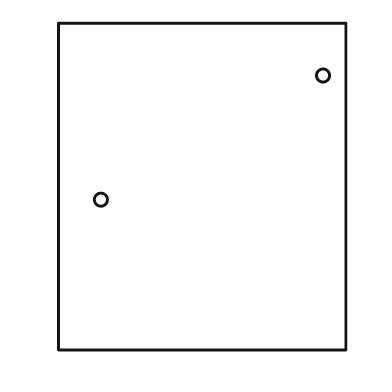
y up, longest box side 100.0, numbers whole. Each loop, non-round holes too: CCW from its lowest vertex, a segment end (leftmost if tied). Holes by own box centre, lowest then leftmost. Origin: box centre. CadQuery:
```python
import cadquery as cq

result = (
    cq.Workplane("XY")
    .moveTo(-44.0, -50.0)
    .lineTo(44.0, -50.0)
    .lineTo(44.0, 50.0)
    .lineTo(-44.0, 50.0)
    .close()
    .moveTo(-31.0, -4.0)
    .circle(2.0)
    .moveTo(37.0, 34.0)
    .circle(2.0)
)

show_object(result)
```